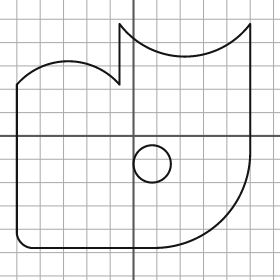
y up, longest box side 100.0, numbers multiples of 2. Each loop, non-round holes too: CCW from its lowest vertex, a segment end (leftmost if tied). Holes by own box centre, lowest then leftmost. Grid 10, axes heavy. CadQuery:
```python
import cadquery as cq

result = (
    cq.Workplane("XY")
    .moveTo(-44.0, -48.0)
    .lineTo(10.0, -48.0)
    .threePointArc((38.0, -36.0), (50.0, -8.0))
    .lineTo(50.0, 48.0)
    .threePointArc((22.0, 34.0), (-6.0, 48.0))
    .lineTo(-6.0, 22.0)
    .threePointArc((-28.0, 32.0), (-50.0, 22.0))
    .lineTo(-50.0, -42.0)
    .threePointArc((-48.0, -46.0), (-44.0, -48.0))
    .close()
    .moveTo(8.0, -12.0)
    .circle(8.0)
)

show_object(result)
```